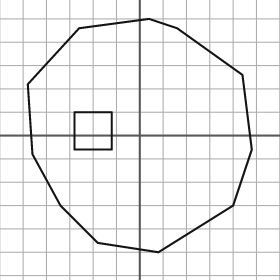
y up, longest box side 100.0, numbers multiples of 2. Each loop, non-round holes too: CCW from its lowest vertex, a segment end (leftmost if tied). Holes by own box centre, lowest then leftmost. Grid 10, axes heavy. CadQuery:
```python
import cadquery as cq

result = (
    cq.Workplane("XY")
    .moveTo(8.0, -50.0)
    .lineTo(40.0, -30.0)
    .lineTo(48.0, -6.0)
    .lineTo(44.0, 26.0)
    .lineTo(16.0, 46.0)
    .lineTo(4.0, 50.0)
    .lineTo(-26.0, 46.0)
    .lineTo(-48.0, 22.0)
    .lineTo(-46.0, -8.0)
    .lineTo(-34.0, -30.0)
    .lineTo(-18.0, -46.0)
    .close()
    .moveTo(-28.0, -6.0)
    .lineTo(-12.0, -6.0)
    .lineTo(-12.0, 10.0)
    .lineTo(-28.0, 10.0)
    .close()
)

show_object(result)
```